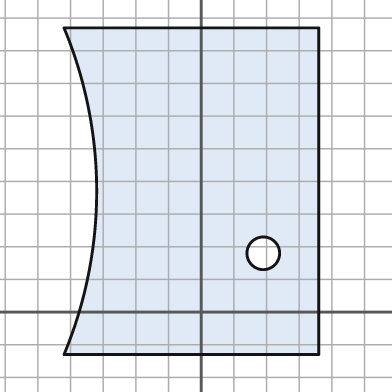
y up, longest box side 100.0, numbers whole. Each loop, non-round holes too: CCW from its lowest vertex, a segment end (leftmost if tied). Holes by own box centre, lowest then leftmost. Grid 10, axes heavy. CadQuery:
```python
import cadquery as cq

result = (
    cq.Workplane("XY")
    .moveTo(-42.0, -13.0)
    .lineTo(36.0, -13.0)
    .lineTo(36.0, 87.0)
    .lineTo(-42.0, 87.0)
    .threePointArc((-32.0, 37.0), (-42.0, -13.0))
    .close()
    .moveTo(19.0, 18.0)
    .circle(5.0)
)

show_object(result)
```